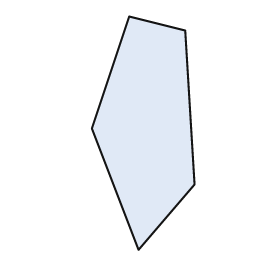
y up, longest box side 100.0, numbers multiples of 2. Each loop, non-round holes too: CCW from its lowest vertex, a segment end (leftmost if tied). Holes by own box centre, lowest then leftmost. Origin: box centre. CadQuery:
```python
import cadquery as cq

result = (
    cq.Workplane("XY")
    .moveTo(-2.0, -50.0)
    .lineTo(22.0, -22.0)
    .lineTo(18.0, 44.0)
    .lineTo(-6.0, 50.0)
    .lineTo(-22.0, 2.0)
    .close()
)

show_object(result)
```